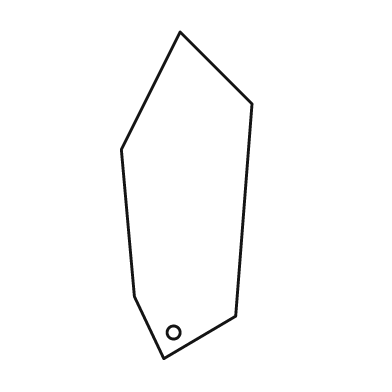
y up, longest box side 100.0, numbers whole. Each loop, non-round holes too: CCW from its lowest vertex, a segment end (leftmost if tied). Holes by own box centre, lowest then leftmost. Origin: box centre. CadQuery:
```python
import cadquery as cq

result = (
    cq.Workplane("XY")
    .moveTo(-7.0, -50.0)
    .lineTo(15.0, -37.0)
    .lineTo(20.0, 28.0)
    .lineTo(-2.0, 50.0)
    .lineTo(-20.0, 14.0)
    .lineTo(-16.0, -31.0)
    .close()
    .moveTo(-4.0, -42.0)
    .circle(2.0)
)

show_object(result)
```